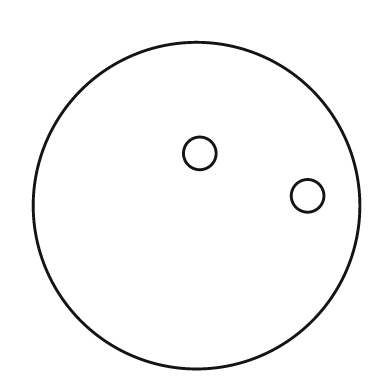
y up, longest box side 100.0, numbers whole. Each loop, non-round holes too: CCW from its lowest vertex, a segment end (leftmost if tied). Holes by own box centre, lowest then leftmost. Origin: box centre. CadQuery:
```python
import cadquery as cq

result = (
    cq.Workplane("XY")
    .moveTo(0.0, 0.0)
    .circle(50.0)
    .moveTo(34.0, 3.0)
    .circle(5.0)
    .moveTo(1.0, 16.0)
    .circle(5.0)
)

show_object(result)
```